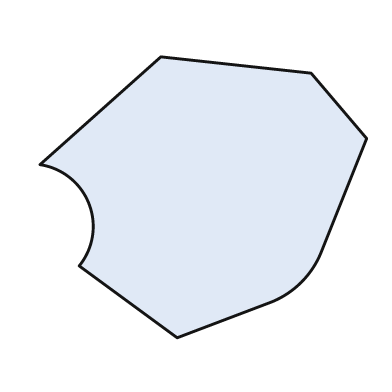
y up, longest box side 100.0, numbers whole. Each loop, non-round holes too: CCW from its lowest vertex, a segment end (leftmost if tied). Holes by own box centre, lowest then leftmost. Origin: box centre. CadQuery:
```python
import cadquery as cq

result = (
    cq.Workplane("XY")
    .moveTo(-8.0, -43.0)
    .lineTo(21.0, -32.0)
    .threePointArc((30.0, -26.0), (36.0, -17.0))
    .lineTo(50.0, 18.0)
    .lineTo(33.0, 38.0)
    .lineTo(-13.0, 43.0)
    .lineTo(-50.0, 10.0)
    .threePointArc((-35.0, -2.0), (-38.0, -21.0))
    .close()
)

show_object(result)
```